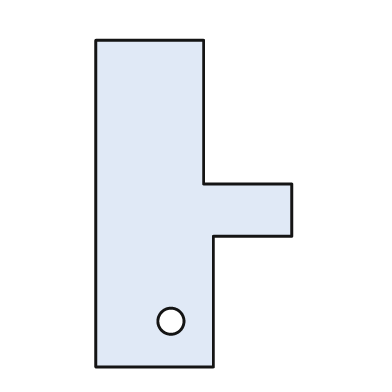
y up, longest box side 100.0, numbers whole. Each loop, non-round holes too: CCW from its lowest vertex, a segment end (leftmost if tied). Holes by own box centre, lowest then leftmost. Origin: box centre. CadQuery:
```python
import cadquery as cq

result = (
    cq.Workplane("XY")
    .moveTo(-30.0, -50.0)
    .lineTo(6.0, -50.0)
    .lineTo(6.0, -10.0)
    .lineTo(30.0, -10.0)
    .lineTo(30.0, 6.0)
    .lineTo(3.0, 6.0)
    .lineTo(3.0, 50.0)
    .lineTo(-30.0, 50.0)
    .close()
    .moveTo(-7.0, -36.0)
    .circle(4.0)
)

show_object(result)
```